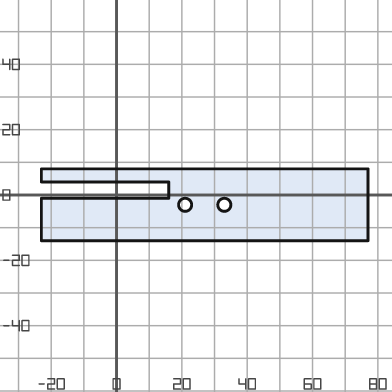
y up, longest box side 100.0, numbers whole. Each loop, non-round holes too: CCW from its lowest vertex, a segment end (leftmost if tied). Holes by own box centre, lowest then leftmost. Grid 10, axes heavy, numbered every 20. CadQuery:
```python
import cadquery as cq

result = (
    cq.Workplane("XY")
    .moveTo(-23.0, -14.0)
    .lineTo(77.0, -14.0)
    .lineTo(77.0, 8.0)
    .lineTo(-23.0, 8.0)
    .lineTo(-23.0, 4.0)
    .lineTo(16.0, 4.0)
    .lineTo(16.0, -1.0)
    .lineTo(-23.0, -1.0)
    .close()
    .moveTo(21.0, -3.0)
    .circle(2.0)
    .moveTo(33.0, -3.0)
    .circle(2.0)
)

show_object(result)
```